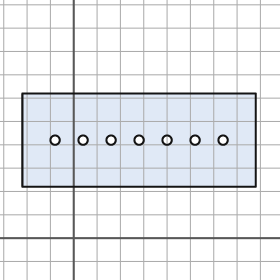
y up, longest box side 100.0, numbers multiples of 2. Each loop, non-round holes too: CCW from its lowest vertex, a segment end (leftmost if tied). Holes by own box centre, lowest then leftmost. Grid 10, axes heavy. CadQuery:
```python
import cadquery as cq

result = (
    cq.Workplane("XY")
    .moveTo(-22.0, 22.0)
    .lineTo(78.0, 22.0)
    .lineTo(78.0, 62.0)
    .lineTo(-22.0, 62.0)
    .close()
    .moveTo(-8.0, 42.0)
    .circle(2.0)
    .moveTo(4.0, 42.0)
    .circle(2.0)
    .moveTo(16.0, 42.0)
    .circle(2.0)
    .moveTo(28.0, 42.0)
    .circle(2.0)
    .moveTo(40.0, 42.0)
    .circle(2.0)
    .moveTo(52.0, 42.0)
    .circle(2.0)
    .moveTo(64.0, 42.0)
    .circle(2.0)
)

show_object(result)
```